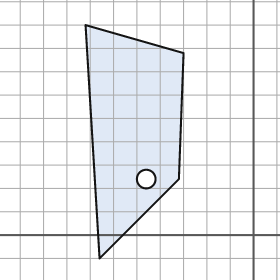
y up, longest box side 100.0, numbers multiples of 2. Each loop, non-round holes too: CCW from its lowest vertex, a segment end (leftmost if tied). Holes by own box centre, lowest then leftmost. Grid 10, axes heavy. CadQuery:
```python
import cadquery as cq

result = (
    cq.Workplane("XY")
    .moveTo(-66.0, -10.0)
    .lineTo(-32.0, 24.0)
    .lineTo(-30.0, 78.0)
    .lineTo(-72.0, 90.0)
    .close()
    .moveTo(-46.0, 24.0)
    .circle(4.0)
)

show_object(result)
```